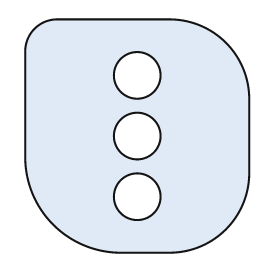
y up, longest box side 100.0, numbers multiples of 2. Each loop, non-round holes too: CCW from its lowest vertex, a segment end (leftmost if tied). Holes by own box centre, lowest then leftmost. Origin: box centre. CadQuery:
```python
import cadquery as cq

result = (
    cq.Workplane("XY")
    .moveTo(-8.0, -50.0)
    .lineTo(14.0, -50.0)
    .threePointArc((38.0, -40.0), (48.0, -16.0))
    .lineTo(48.0, 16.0)
    .threePointArc((38.0, 40.0), (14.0, 50.0))
    .lineTo(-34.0, 50.0)
    .threePointArc((-44.0, 46.0), (-48.0, 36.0))
    .lineTo(-48.0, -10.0)
    .threePointArc((-36.0, -38.0), (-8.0, -50.0))
    .close()
    .moveTo(0.0, -26.0)
    .circle(10.0)
    .moveTo(0.0, 0.0)
    .circle(10.0)
    .moveTo(0.0, 26.0)
    .circle(10.0)
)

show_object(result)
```